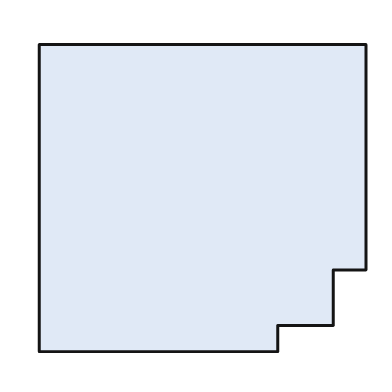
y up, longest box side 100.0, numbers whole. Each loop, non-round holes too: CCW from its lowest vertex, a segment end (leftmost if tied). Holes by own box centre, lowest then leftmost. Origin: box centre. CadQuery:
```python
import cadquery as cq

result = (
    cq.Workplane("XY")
    .moveTo(-50.0, -47.0)
    .lineTo(23.0, -47.0)
    .lineTo(23.0, -39.0)
    .lineTo(40.0, -39.0)
    .lineTo(40.0, -22.0)
    .lineTo(50.0, -22.0)
    .lineTo(50.0, 47.0)
    .lineTo(-50.0, 47.0)
    .close()
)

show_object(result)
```